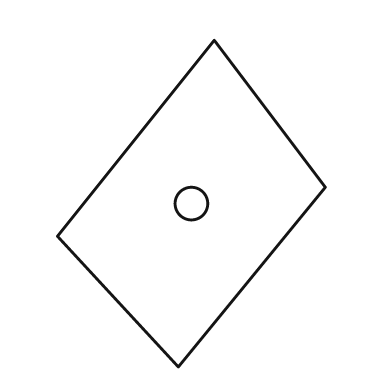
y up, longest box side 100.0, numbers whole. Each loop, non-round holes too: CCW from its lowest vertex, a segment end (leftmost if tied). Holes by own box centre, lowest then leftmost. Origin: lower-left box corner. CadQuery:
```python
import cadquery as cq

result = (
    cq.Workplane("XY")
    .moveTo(37.0, 0.0)
    .lineTo(82.0, 55.0)
    .lineTo(48.0, 100.0)
    .lineTo(0.0, 40.0)
    .close()
    .moveTo(41.0, 50.0)
    .circle(5.0)
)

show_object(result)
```